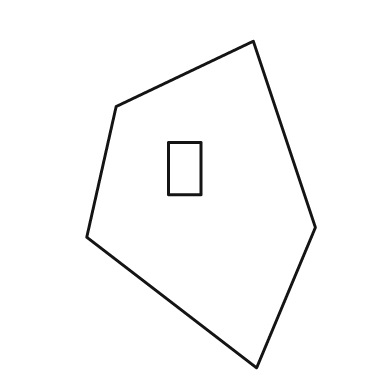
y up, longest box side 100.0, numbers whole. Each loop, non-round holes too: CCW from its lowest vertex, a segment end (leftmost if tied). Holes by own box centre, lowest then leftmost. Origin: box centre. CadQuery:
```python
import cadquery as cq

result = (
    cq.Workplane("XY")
    .moveTo(17.0, -50.0)
    .lineTo(35.0, -7.0)
    .lineTo(16.0, 50.0)
    .lineTo(-26.0, 30.0)
    .lineTo(-35.0, -10.0)
    .close()
    .moveTo(-10.0, 3.0)
    .lineTo(0.0, 3.0)
    .lineTo(0.0, 19.0)
    .lineTo(-10.0, 19.0)
    .close()
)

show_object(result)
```